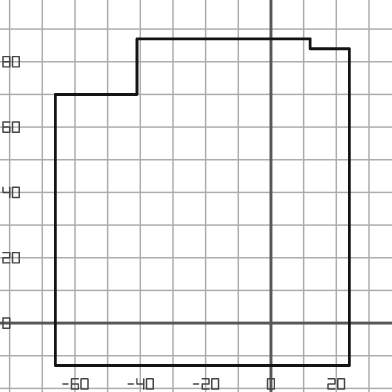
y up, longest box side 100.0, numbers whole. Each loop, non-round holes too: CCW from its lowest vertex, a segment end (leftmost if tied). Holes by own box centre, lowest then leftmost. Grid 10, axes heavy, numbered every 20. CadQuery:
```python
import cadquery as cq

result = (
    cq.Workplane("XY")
    .moveTo(-66.0, -13.0)
    .lineTo(24.0, -13.0)
    .lineTo(24.0, 84.0)
    .lineTo(12.0, 84.0)
    .lineTo(12.0, 87.0)
    .lineTo(-41.0, 87.0)
    .lineTo(-41.0, 70.0)
    .lineTo(-66.0, 70.0)
    .close()
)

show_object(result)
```